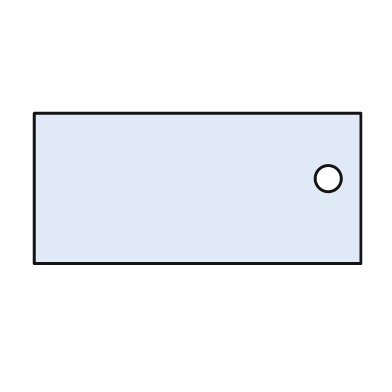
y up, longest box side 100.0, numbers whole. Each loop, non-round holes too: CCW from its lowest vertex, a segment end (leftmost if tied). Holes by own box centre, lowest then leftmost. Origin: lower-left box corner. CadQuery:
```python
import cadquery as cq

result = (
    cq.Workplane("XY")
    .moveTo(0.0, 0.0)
    .lineTo(100.0, 0.0)
    .lineTo(100.0, 46.0)
    .lineTo(0.0, 46.0)
    .close()
    .moveTo(90.0, 26.0)
    .circle(4.0)
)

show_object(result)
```